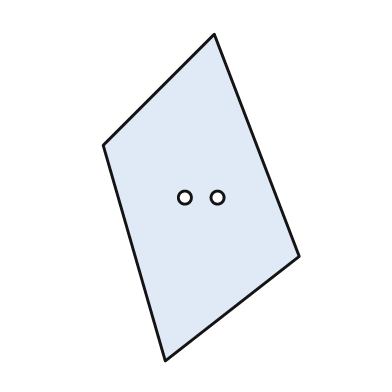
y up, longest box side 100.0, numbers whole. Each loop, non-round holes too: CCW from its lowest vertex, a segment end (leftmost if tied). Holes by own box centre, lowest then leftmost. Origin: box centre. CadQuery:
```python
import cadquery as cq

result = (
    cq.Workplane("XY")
    .moveTo(-11.0, -50.0)
    .lineTo(30.0, -18.0)
    .lineTo(4.0, 50.0)
    .lineTo(-30.0, 16.0)
    .close()
    .moveTo(-5.0, 0.0)
    .circle(2.0)
    .moveTo(5.0, 0.0)
    .circle(2.0)
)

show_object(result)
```